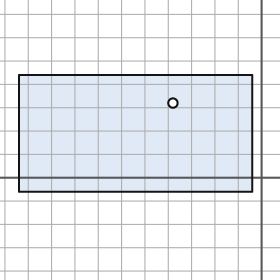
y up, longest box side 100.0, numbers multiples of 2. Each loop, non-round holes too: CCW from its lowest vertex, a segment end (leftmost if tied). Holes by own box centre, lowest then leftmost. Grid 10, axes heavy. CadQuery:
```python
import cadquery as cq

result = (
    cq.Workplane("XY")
    .moveTo(-104.0, -6.0)
    .lineTo(-4.0, -6.0)
    .lineTo(-4.0, 44.0)
    .lineTo(-104.0, 44.0)
    .close()
    .moveTo(-38.0, 32.0)
    .circle(2.0)
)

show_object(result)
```